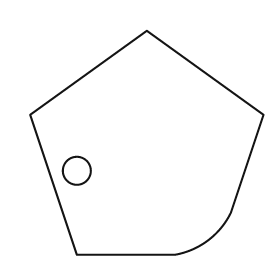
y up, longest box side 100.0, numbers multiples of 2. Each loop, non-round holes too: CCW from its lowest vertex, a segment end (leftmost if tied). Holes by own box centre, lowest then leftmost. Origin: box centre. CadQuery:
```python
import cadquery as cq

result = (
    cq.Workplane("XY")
    .moveTo(-30.0, -48.0)
    .lineTo(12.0, -48.0)
    .threePointArc((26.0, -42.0), (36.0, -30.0))
    .lineTo(50.0, 12.0)
    .lineTo(0.0, 48.0)
    .lineTo(-50.0, 12.0)
    .close()
    .moveTo(-30.0, -12.0)
    .circle(6.0)
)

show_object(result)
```